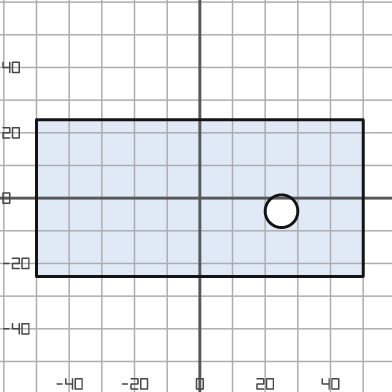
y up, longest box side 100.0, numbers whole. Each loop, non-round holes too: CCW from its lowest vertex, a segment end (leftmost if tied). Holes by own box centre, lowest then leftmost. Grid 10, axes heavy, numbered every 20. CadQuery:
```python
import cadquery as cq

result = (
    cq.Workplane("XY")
    .moveTo(-50.0, -24.0)
    .lineTo(50.0, -24.0)
    .lineTo(50.0, 24.0)
    .lineTo(-50.0, 24.0)
    .close()
    .moveTo(25.0, -4.0)
    .circle(5.0)
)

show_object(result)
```